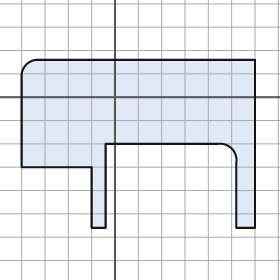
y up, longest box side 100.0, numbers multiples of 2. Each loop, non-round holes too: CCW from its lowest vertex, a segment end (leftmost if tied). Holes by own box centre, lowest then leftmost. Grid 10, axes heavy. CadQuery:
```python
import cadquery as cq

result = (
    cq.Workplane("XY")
    .moveTo(-10.0, -56.0)
    .lineTo(-4.0, -56.0)
    .lineTo(-4.0, -20.0)
    .lineTo(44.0, -20.0)
    .threePointArc((50.0, -22.0), (52.0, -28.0))
    .lineTo(52.0, -56.0)
    .lineTo(60.0, -56.0)
    .lineTo(60.0, 16.0)
    .lineTo(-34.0, 16.0)
    .threePointArc((-38.0, 14.0), (-40.0, 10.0))
    .lineTo(-40.0, -30.0)
    .lineTo(-10.0, -30.0)
    .close()
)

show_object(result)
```